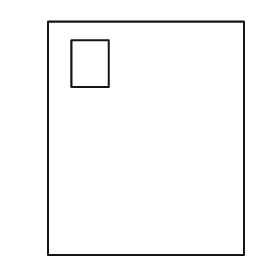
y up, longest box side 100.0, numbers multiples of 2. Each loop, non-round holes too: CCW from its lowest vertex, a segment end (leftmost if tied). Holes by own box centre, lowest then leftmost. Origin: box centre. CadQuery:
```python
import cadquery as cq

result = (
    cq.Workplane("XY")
    .moveTo(-42.0, -50.0)
    .lineTo(42.0, -50.0)
    .lineTo(42.0, 50.0)
    .lineTo(-42.0, 50.0)
    .close()
    .moveTo(-32.0, 22.0)
    .lineTo(-16.0, 22.0)
    .lineTo(-16.0, 42.0)
    .lineTo(-32.0, 42.0)
    .close()
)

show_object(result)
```